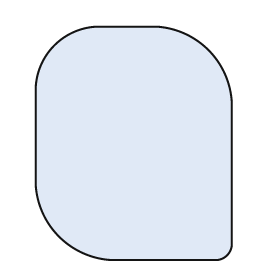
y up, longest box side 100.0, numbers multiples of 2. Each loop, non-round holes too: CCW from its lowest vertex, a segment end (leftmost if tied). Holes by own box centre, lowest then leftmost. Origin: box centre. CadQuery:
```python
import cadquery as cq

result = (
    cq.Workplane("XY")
    .moveTo(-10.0, -50.0)
    .lineTo(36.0, -50.0)
    .threePointArc((40.0, -48.0), (42.0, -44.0))
    .lineTo(42.0, 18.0)
    .threePointArc((32.0, 40.0), (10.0, 50.0))
    .lineTo(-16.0, 50.0)
    .threePointArc((-34.0, 42.0), (-42.0, 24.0))
    .lineTo(-42.0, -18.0)
    .threePointArc((-32.0, -40.0), (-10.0, -50.0))
    .close()
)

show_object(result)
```